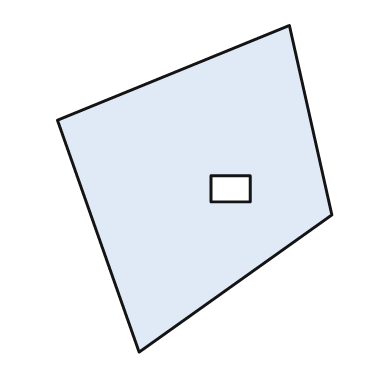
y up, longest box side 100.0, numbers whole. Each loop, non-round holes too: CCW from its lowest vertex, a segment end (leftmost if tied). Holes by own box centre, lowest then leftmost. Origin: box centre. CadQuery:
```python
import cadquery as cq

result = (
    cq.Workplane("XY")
    .moveTo(-17.0, -50.0)
    .lineTo(42.0, -8.0)
    .lineTo(29.0, 50.0)
    .lineTo(-42.0, 21.0)
    .close()
    .moveTo(5.0, -4.0)
    .lineTo(17.0, -4.0)
    .lineTo(17.0, 4.0)
    .lineTo(5.0, 4.0)
    .close()
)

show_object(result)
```